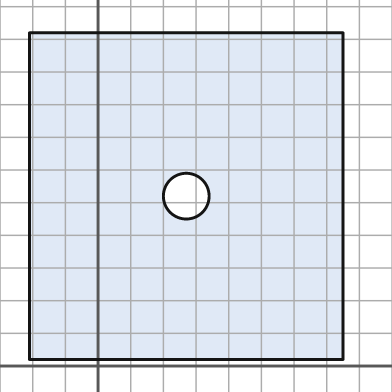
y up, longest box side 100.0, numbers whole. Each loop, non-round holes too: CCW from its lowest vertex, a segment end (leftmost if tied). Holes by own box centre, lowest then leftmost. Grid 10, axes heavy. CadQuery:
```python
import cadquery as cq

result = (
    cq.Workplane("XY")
    .moveTo(-21.0, 2.0)
    .lineTo(75.0, 2.0)
    .lineTo(75.0, 102.0)
    .lineTo(-21.0, 102.0)
    .close()
    .moveTo(27.0, 52.0)
    .circle(7.0)
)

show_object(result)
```